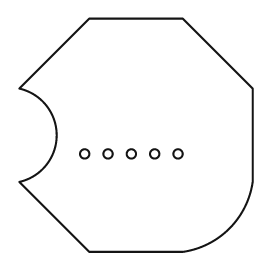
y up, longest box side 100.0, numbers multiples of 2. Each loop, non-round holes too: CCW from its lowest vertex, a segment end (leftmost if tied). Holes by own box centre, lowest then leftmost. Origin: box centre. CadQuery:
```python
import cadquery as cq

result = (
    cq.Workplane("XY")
    .moveTo(-20.0, -50.0)
    .lineTo(20.0, -50.0)
    .threePointArc((40.0, -40.0), (50.0, -20.0))
    .lineTo(50.0, 20.0)
    .lineTo(20.0, 50.0)
    .lineTo(-20.0, 50.0)
    .lineTo(-50.0, 20.0)
    .threePointArc((-34.0, 0.0), (-50.0, -20.0))
    .close()
    .moveTo(-22.0, -8.0)
    .circle(2.0)
    .moveTo(-12.0, -8.0)
    .circle(2.0)
    .moveTo(-2.0, -8.0)
    .circle(2.0)
    .moveTo(8.0, -8.0)
    .circle(2.0)
    .moveTo(18.0, -8.0)
    .circle(2.0)
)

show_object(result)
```